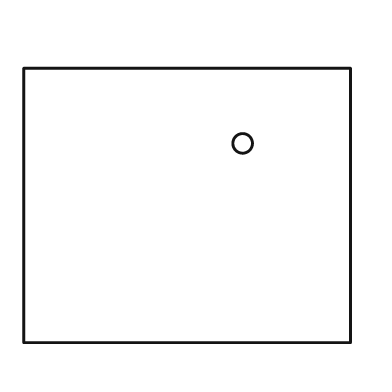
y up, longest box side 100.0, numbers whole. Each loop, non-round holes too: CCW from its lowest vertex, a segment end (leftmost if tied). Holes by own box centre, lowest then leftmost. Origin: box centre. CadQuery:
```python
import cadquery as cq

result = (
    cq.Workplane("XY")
    .moveTo(-50.0, -42.0)
    .lineTo(50.0, -42.0)
    .lineTo(50.0, 42.0)
    .lineTo(-50.0, 42.0)
    .close()
    .moveTo(17.0, 19.0)
    .circle(3.0)
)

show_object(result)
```